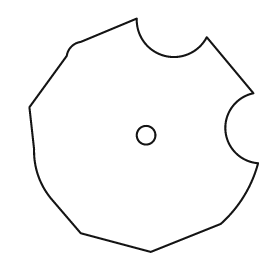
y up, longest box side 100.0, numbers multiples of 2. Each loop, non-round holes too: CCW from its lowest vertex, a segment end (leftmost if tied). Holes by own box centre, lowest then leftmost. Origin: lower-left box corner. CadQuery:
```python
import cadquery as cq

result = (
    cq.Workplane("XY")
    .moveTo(52.0, 0.0)
    .lineTo(82.0, 12.0)
    .threePointArc((92.0, 24.0), (98.0, 38.0))
    .threePointArc((84.0, 52.0), (96.0, 68.0))
    .lineTo(76.0, 92.0)
    .threePointArc((58.0, 84.0), (46.0, 100.0))
    .lineTo(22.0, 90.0)
    .threePointArc((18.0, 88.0), (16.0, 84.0))
    .lineTo(0.0, 62.0)
    .lineTo(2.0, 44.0)
    .threePointArc((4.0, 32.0), (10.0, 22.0))
    .lineTo(22.0, 8.0)
    .close()
    .moveTo(50.0, 50.0)
    .circle(4.0)
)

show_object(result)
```